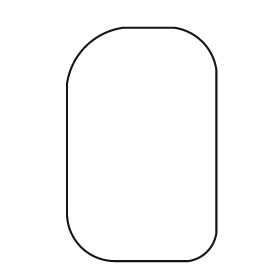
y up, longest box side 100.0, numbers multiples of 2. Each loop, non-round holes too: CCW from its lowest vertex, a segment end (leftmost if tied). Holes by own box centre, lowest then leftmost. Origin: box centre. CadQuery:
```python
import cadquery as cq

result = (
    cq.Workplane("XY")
    .moveTo(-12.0, -50.0)
    .lineTo(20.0, -50.0)
    .threePointArc((28.0, -46.0), (32.0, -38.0))
    .lineTo(32.0, 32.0)
    .threePointArc((26.0, 44.0), (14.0, 50.0))
    .lineTo(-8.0, 50.0)
    .threePointArc((-24.0, 42.0), (-32.0, 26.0))
    .lineTo(-32.0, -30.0)
    .threePointArc((-26.0, -44.0), (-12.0, -50.0))
    .close()
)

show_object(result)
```